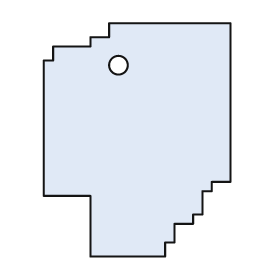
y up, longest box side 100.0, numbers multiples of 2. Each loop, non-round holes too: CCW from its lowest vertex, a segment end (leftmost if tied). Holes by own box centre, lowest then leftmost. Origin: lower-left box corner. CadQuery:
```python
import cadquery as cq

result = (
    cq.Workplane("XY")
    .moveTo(20.0, 0.0)
    .lineTo(52.0, 0.0)
    .lineTo(52.0, 6.0)
    .lineTo(56.0, 6.0)
    .lineTo(56.0, 14.0)
    .lineTo(64.0, 14.0)
    .lineTo(64.0, 18.0)
    .lineTo(68.0, 18.0)
    .lineTo(68.0, 28.0)
    .lineTo(72.0, 28.0)
    .lineTo(72.0, 32.0)
    .lineTo(80.0, 32.0)
    .lineTo(80.0, 100.0)
    .lineTo(28.0, 100.0)
    .lineTo(28.0, 94.0)
    .lineTo(20.0, 94.0)
    .lineTo(20.0, 90.0)
    .lineTo(4.0, 90.0)
    .lineTo(4.0, 84.0)
    .lineTo(0.0, 84.0)
    .lineTo(0.0, 26.0)
    .lineTo(20.0, 26.0)
    .close()
    .moveTo(32.0, 82.0)
    .circle(4.0)
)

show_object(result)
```